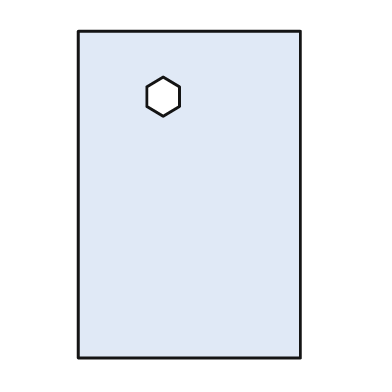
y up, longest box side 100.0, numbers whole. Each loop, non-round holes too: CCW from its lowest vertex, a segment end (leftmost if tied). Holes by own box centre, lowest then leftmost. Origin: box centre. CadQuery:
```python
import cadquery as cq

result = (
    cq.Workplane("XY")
    .moveTo(-34.0, -50.0)
    .lineTo(34.0, -50.0)
    .lineTo(34.0, 50.0)
    .lineTo(-34.0, 50.0)
    .close()
    .moveTo(-8.0, 24.0)
    .lineTo(-3.0, 27.0)
    .lineTo(-3.0, 33.0)
    .lineTo(-8.0, 36.0)
    .lineTo(-13.0, 33.0)
    .lineTo(-13.0, 27.0)
    .close()
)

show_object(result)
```